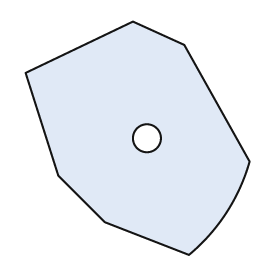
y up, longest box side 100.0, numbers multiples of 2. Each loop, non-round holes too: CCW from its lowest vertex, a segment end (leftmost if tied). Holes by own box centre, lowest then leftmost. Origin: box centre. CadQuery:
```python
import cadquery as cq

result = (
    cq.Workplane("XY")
    .moveTo(22.0, -50.0)
    .threePointArc((38.0, -32.0), (48.0, -10.0))
    .lineTo(20.0, 40.0)
    .lineTo(-2.0, 50.0)
    .lineTo(-48.0, 28.0)
    .lineTo(-34.0, -16.0)
    .lineTo(-14.0, -36.0)
    .close()
    .moveTo(4.0, 0.0)
    .circle(6.0)
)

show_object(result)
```